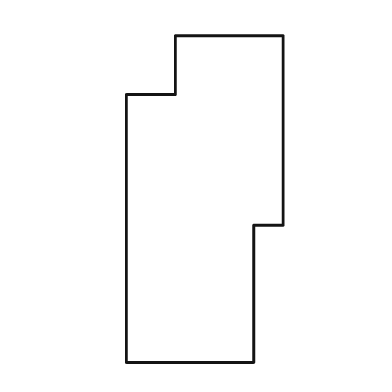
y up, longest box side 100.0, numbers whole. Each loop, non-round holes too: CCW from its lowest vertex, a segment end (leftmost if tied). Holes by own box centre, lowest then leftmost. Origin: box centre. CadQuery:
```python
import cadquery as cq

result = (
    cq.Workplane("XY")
    .moveTo(-24.0, -50.0)
    .lineTo(15.0, -50.0)
    .lineTo(15.0, -8.0)
    .lineTo(24.0, -8.0)
    .lineTo(24.0, 50.0)
    .lineTo(-9.0, 50.0)
    .lineTo(-9.0, 32.0)
    .lineTo(-24.0, 32.0)
    .close()
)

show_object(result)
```